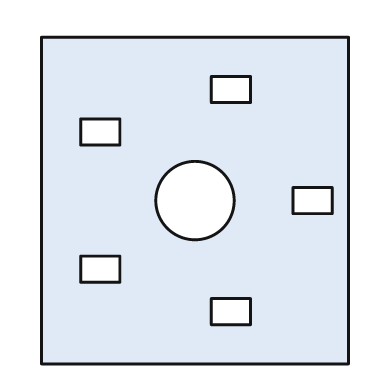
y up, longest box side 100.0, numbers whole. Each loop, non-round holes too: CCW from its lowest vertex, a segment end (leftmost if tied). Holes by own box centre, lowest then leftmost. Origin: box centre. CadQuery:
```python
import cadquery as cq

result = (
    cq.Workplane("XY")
    .moveTo(-47.0, -50.0)
    .lineTo(47.0, -50.0)
    .lineTo(47.0, 50.0)
    .lineTo(-47.0, 50.0)
    .close()
    .moveTo(5.0, -38.0)
    .lineTo(17.0, -38.0)
    .lineTo(17.0, -30.0)
    .lineTo(5.0, -30.0)
    .close()
    .moveTo(-35.0, -25.0)
    .lineTo(-23.0, -25.0)
    .lineTo(-23.0, -17.0)
    .lineTo(-35.0, -17.0)
    .close()
    .moveTo(0.0, 0.0)
    .circle(12.0)
    .moveTo(30.0, -4.0)
    .lineTo(42.0, -4.0)
    .lineTo(42.0, 4.0)
    .lineTo(30.0, 4.0)
    .close()
    .moveTo(-35.0, 17.0)
    .lineTo(-23.0, 17.0)
    .lineTo(-23.0, 25.0)
    .lineTo(-35.0, 25.0)
    .close()
    .moveTo(5.0, 30.0)
    .lineTo(17.0, 30.0)
    .lineTo(17.0, 38.0)
    .lineTo(5.0, 38.0)
    .close()
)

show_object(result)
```